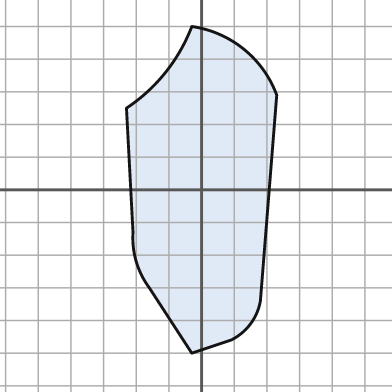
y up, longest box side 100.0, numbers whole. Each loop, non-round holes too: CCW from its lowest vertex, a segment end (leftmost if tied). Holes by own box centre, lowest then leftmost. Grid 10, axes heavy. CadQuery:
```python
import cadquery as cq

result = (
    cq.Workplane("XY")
    .moveTo(-3.0, -50.0)
    .lineTo(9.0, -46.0)
    .threePointArc((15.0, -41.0), (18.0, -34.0))
    .lineTo(23.0, 29.0)
    .threePointArc((13.0, 43.0), (-3.0, 50.0))
    .threePointArc((-11.0, 36.0), (-23.0, 25.0))
    .lineTo(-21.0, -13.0)
    .threePointArc((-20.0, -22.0), (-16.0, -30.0))
    .close()
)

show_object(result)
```